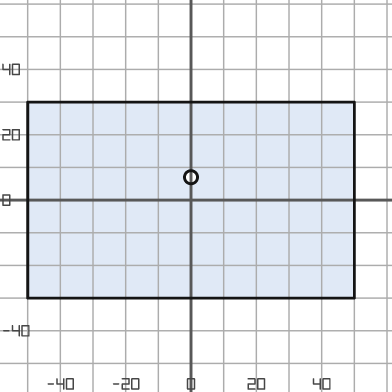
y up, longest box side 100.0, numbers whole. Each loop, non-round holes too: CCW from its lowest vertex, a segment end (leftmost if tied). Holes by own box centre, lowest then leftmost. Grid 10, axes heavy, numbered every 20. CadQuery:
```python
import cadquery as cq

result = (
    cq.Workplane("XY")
    .moveTo(-50.0, -30.0)
    .lineTo(50.0, -30.0)
    .lineTo(50.0, 30.0)
    .lineTo(-50.0, 30.0)
    .close()
    .moveTo(0.0, 7.0)
    .circle(2.0)
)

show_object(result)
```